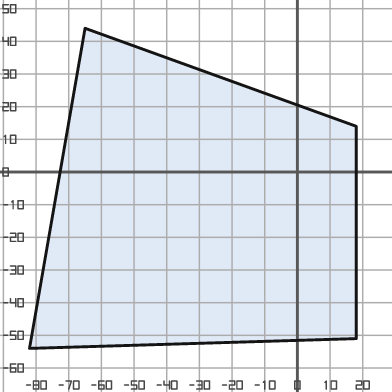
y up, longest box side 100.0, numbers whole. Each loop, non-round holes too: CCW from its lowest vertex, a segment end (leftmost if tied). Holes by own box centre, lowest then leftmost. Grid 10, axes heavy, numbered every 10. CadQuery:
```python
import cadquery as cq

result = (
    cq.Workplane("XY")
    .moveTo(-82.0, -54.0)
    .lineTo(18.0, -51.0)
    .lineTo(18.0, 14.0)
    .lineTo(-65.0, 44.0)
    .close()
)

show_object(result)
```